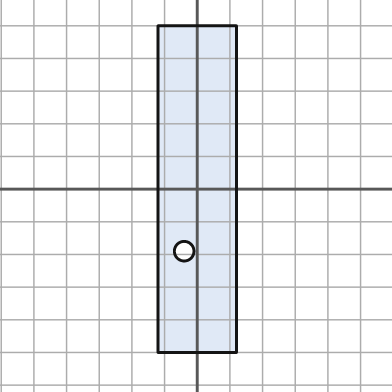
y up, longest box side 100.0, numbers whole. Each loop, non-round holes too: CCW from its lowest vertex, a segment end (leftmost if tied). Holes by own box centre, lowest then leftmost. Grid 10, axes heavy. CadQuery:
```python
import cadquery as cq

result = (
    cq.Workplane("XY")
    .moveTo(-12.0, -50.0)
    .lineTo(12.0, -50.0)
    .lineTo(12.0, 50.0)
    .lineTo(-12.0, 50.0)
    .close()
    .moveTo(-4.0, -19.0)
    .circle(3.0)
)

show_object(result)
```